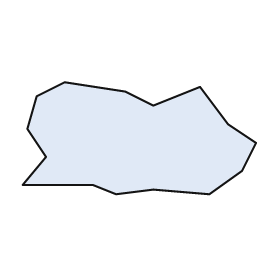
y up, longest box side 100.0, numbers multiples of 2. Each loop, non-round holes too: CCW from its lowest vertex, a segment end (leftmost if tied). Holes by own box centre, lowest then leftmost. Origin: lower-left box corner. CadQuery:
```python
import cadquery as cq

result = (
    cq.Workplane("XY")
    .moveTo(40.0, 0.0)
    .lineTo(56.0, 2.0)
    .lineTo(80.0, 0.0)
    .lineTo(94.0, 10.0)
    .lineTo(100.0, 22.0)
    .lineTo(88.0, 30.0)
    .lineTo(76.0, 46.0)
    .lineTo(56.0, 38.0)
    .lineTo(44.0, 44.0)
    .lineTo(18.0, 48.0)
    .lineTo(6.0, 42.0)
    .lineTo(2.0, 28.0)
    .lineTo(10.0, 16.0)
    .lineTo(0.0, 4.0)
    .lineTo(30.0, 4.0)
    .close()
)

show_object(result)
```